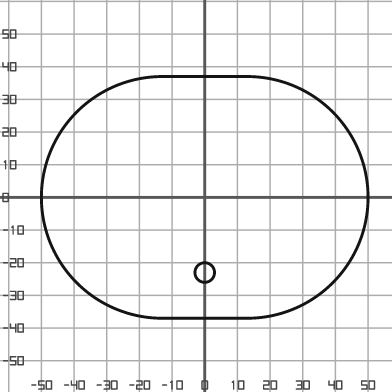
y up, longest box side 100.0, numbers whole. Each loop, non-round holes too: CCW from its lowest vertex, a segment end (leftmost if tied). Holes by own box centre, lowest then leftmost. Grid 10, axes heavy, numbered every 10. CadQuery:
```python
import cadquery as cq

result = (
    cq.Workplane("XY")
    .moveTo(-13.0, -37.0)
    .lineTo(13.0, -37.0)
    .threePointArc((50.0, 0.0), (13.0, 37.0))
    .lineTo(-13.0, 37.0)
    .threePointArc((-50.0, 0.0), (-13.0, -37.0))
    .close()
    .moveTo(0.0, -23.0)
    .circle(3.0)
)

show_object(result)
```